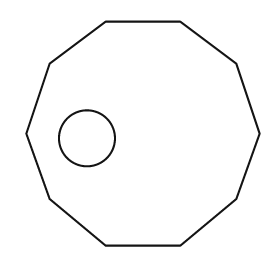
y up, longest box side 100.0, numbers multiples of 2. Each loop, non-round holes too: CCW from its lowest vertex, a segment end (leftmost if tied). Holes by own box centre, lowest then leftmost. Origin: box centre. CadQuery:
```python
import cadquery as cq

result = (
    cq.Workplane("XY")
    .moveTo(-16.0, -48.0)
    .lineTo(16.0, -48.0)
    .lineTo(40.0, -28.0)
    .lineTo(50.0, 0.0)
    .lineTo(40.0, 30.0)
    .lineTo(16.0, 48.0)
    .lineTo(-16.0, 48.0)
    .lineTo(-40.0, 30.0)
    .lineTo(-50.0, 0.0)
    .lineTo(-40.0, -28.0)
    .close()
    .moveTo(-24.0, -2.0)
    .circle(12.0)
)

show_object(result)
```